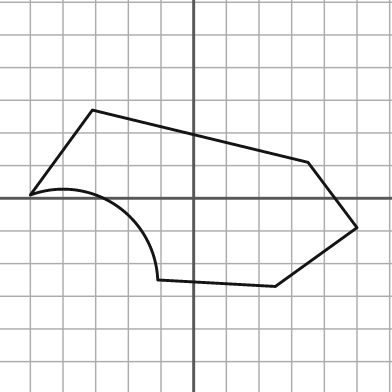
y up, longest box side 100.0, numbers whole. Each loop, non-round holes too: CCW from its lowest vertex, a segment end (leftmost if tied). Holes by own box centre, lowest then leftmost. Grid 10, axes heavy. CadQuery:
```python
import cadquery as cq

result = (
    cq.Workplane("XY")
    .moveTo(25.0, -27.0)
    .lineTo(50.0, -9.0)
    .lineTo(35.0, 11.0)
    .lineTo(-31.0, 27.0)
    .lineTo(-50.0, 1.0)
    .threePointArc((-24.0, -2.0), (-11.0, -25.0))
    .close()
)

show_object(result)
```